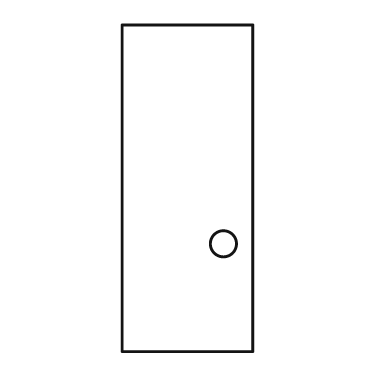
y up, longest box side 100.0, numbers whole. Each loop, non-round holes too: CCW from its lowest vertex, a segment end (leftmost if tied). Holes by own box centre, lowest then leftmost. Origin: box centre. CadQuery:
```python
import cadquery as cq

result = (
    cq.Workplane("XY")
    .moveTo(-20.0, -50.0)
    .lineTo(20.0, -50.0)
    .lineTo(20.0, 50.0)
    .lineTo(-20.0, 50.0)
    .close()
    .moveTo(11.0, -17.0)
    .circle(4.0)
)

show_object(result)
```